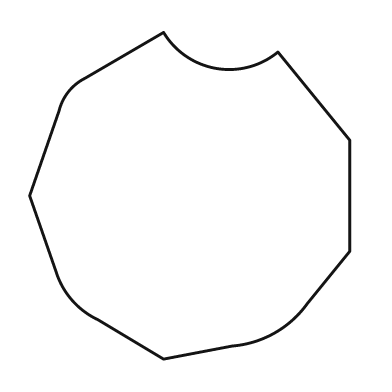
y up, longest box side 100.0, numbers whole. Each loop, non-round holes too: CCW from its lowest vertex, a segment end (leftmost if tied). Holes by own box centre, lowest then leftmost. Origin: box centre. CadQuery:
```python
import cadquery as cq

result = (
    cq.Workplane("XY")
    .moveTo(-8.0, -50.0)
    .lineTo(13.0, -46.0)
    .threePointArc((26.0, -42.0), (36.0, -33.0))
    .lineTo(49.0, -17.0)
    .lineTo(49.0, 17.0)
    .lineTo(27.0, 44.0)
    .threePointArc((8.0, 39.0), (-8.0, 50.0))
    .lineTo(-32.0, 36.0)
    .threePointArc((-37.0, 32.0), (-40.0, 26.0))
    .lineTo(-49.0, 0.0)
    .lineTo(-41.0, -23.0)
    .threePointArc((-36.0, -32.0), (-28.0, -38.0))
    .close()
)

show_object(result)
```